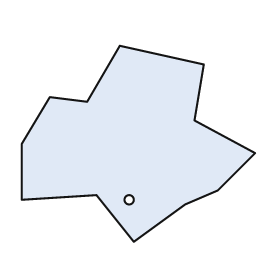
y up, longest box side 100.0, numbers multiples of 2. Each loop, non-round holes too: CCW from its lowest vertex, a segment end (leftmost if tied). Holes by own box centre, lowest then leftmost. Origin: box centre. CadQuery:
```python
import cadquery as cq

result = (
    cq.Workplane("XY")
    .moveTo(-2.0, -42.0)
    .lineTo(20.0, -26.0)
    .lineTo(34.0, -20.0)
    .lineTo(50.0, -4.0)
    .lineTo(24.0, 10.0)
    .lineTo(28.0, 34.0)
    .lineTo(-8.0, 42.0)
    .lineTo(-22.0, 18.0)
    .lineTo(-38.0, 20.0)
    .lineTo(-50.0, 0.0)
    .lineTo(-50.0, -24.0)
    .lineTo(-18.0, -22.0)
    .close()
    .moveTo(-4.0, -24.0)
    .circle(2.0)
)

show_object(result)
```